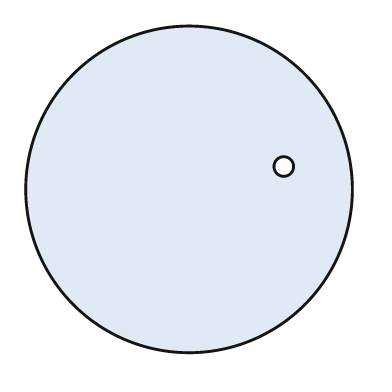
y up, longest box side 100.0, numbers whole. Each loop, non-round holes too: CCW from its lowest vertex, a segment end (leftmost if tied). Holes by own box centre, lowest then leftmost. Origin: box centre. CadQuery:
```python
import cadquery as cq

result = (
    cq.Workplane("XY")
    .moveTo(0.0, 0.0)
    .circle(50.0)
    .moveTo(29.0, 7.0)
    .circle(3.0)
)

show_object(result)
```